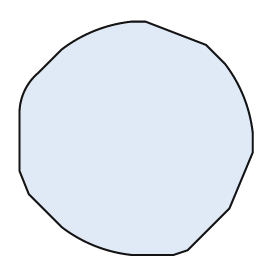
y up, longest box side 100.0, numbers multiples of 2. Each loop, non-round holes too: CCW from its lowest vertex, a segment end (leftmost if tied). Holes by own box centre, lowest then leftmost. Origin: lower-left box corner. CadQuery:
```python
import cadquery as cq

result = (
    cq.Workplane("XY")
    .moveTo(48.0, 0.0)
    .lineTo(66.0, 0.0)
    .lineTo(72.0, 2.0)
    .lineTo(90.0, 20.0)
    .lineTo(100.0, 44.0)
    .lineTo(100.0, 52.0)
    .threePointArc((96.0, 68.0), (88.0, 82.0))
    .lineTo(80.0, 90.0)
    .lineTo(54.0, 100.0)
    .lineTo(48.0, 100.0)
    .threePointArc((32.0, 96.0), (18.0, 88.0))
    .lineTo(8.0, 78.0)
    .threePointArc((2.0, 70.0), (0.0, 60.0))
    .lineTo(0.0, 36.0)
    .lineTo(4.0, 26.0)
    .lineTo(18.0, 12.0)
    .threePointArc((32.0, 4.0), (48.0, 0.0))
    .close()
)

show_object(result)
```